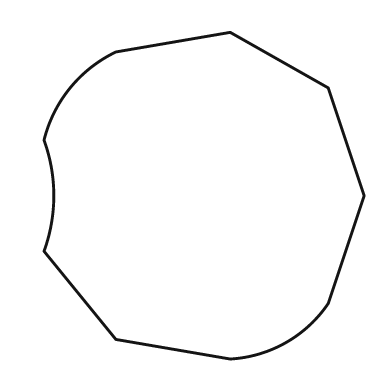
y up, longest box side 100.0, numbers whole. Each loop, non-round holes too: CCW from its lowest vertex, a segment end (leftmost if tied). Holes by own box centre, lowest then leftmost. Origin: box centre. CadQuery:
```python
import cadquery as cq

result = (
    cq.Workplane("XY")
    .moveTo(8.0, -50.0)
    .threePointArc((25.0, -45.0), (38.0, -33.0))
    .lineTo(49.0, 0.0)
    .lineTo(38.0, 33.0)
    .lineTo(8.0, 50.0)
    .lineTo(-27.0, 44.0)
    .threePointArc((-41.0, 33.0), (-49.0, 17.0))
    .threePointArc((-46.0, 0.0), (-49.0, -17.0))
    .lineTo(-27.0, -44.0)
    .close()
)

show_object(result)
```